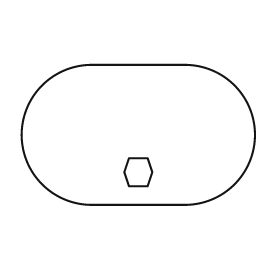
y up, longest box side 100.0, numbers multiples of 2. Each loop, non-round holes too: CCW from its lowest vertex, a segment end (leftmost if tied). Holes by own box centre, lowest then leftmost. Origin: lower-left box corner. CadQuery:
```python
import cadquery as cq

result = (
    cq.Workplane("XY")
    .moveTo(30.0, 0.0)
    .lineTo(70.0, 0.0)
    .threePointArc((100.0, 30.0), (70.0, 60.0))
    .lineTo(30.0, 60.0)
    .threePointArc((0.0, 30.0), (30.0, 0.0))
    .close()
    .moveTo(46.0, 8.0)
    .lineTo(54.0, 8.0)
    .lineTo(56.0, 14.0)
    .lineTo(54.0, 20.0)
    .lineTo(46.0, 20.0)
    .lineTo(44.0, 14.0)
    .close()
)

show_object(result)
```